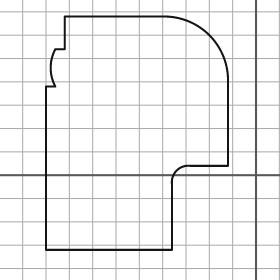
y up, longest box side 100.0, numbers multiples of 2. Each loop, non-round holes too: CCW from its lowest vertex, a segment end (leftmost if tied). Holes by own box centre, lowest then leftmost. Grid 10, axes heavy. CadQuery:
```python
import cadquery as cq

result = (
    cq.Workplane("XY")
    .moveTo(-90.0, -32.0)
    .lineTo(-36.0, -32.0)
    .lineTo(-36.0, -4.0)
    .threePointArc((-34.0, 2.0), (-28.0, 4.0))
    .lineTo(-12.0, 4.0)
    .lineTo(-12.0, 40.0)
    .threePointArc((-20.0, 60.0), (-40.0, 68.0))
    .lineTo(-82.0, 68.0)
    .lineTo(-82.0, 54.0)
    .lineTo(-86.0, 54.0)
    .threePointArc((-88.0, 46.0), (-86.0, 38.0))
    .lineTo(-90.0, 38.0)
    .close()
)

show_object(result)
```